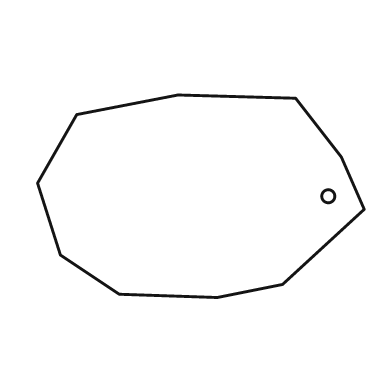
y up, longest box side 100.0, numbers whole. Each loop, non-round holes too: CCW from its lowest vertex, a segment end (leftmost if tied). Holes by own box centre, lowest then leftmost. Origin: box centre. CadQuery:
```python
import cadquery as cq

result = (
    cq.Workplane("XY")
    .moveTo(5.0, -31.0)
    .lineTo(25.0, -27.0)
    .lineTo(50.0, -4.0)
    .lineTo(43.0, 12.0)
    .lineTo(29.0, 30.0)
    .lineTo(-7.0, 31.0)
    .lineTo(-38.0, 25.0)
    .lineTo(-50.0, 4.0)
    .lineTo(-43.0, -18.0)
    .lineTo(-25.0, -30.0)
    .close()
    .moveTo(39.0, 0.0)
    .circle(2.0)
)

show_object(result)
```